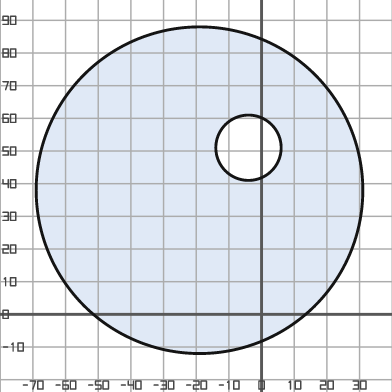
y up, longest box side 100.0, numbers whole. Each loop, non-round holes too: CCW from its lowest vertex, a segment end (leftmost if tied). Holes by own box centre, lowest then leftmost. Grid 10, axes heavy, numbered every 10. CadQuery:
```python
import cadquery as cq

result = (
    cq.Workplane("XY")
    .moveTo(-19.0, 38.0)
    .circle(50.0)
    .moveTo(-4.0, 51.0)
    .circle(10.0)
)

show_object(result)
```